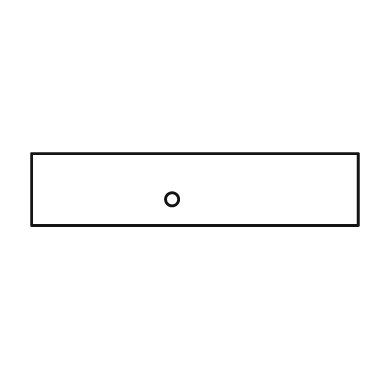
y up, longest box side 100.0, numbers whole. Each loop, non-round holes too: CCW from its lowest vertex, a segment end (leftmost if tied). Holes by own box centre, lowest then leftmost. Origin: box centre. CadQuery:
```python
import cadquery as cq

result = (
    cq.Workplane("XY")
    .moveTo(-50.0, -11.0)
    .lineTo(50.0, -11.0)
    .lineTo(50.0, 11.0)
    .lineTo(-50.0, 11.0)
    .close()
    .moveTo(-7.0, -3.0)
    .circle(2.0)
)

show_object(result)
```